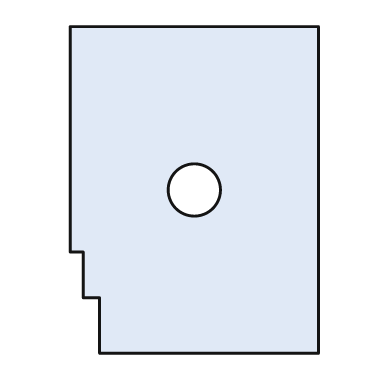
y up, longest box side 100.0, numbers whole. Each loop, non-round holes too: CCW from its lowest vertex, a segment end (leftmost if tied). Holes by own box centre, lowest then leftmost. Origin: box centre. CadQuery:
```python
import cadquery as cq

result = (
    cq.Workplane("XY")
    .moveTo(-29.0, -50.0)
    .lineTo(38.0, -50.0)
    .lineTo(38.0, 50.0)
    .lineTo(-38.0, 50.0)
    .lineTo(-38.0, -19.0)
    .lineTo(-34.0, -19.0)
    .lineTo(-34.0, -33.0)
    .lineTo(-29.0, -33.0)
    .close()
    .moveTo(0.0, 0.0)
    .circle(8.0)
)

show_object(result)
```